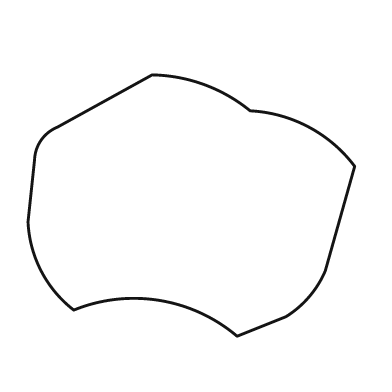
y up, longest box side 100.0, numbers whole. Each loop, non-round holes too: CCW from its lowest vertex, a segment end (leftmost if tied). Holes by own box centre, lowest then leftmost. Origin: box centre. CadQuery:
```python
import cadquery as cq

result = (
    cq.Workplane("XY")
    .moveTo(14.0, -40.0)
    .lineTo(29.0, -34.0)
    .threePointArc((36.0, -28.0), (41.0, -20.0))
    .lineTo(50.0, 12.0)
    .threePointArc((36.0, 24.0), (18.0, 29.0))
    .threePointArc((4.0, 37.0), (-12.0, 40.0))
    .lineTo(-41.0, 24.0)
    .threePointArc((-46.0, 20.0), (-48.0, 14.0))
    .lineTo(-50.0, -5.0)
    .threePointArc((-46.0, -20.0), (-36.0, -32.0))
    .threePointArc((-10.0, -29.0), (14.0, -40.0))
    .close()
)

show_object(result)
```